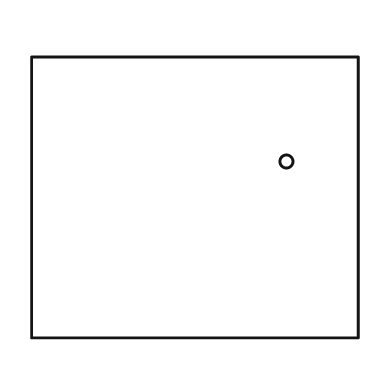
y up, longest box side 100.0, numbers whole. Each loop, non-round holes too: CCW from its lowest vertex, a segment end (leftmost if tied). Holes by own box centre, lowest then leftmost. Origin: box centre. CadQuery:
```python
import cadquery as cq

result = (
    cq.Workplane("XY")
    .moveTo(-50.0, -43.0)
    .lineTo(50.0, -43.0)
    .lineTo(50.0, 43.0)
    .lineTo(-50.0, 43.0)
    .close()
    .moveTo(28.0, 11.0)
    .circle(2.0)
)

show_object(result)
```